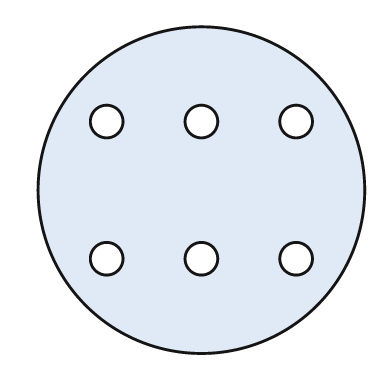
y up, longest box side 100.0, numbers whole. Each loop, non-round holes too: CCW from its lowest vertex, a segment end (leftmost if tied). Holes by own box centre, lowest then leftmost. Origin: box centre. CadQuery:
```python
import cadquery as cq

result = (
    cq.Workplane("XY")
    .moveTo(0.0, 0.0)
    .circle(50.0)
    .moveTo(-29.0, -21.0)
    .circle(5.0)
    .moveTo(0.0, -21.0)
    .circle(5.0)
    .moveTo(29.0, -21.0)
    .circle(5.0)
    .moveTo(-29.0, 21.0)
    .circle(5.0)
    .moveTo(0.0, 21.0)
    .circle(5.0)
    .moveTo(29.0, 21.0)
    .circle(5.0)
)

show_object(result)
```